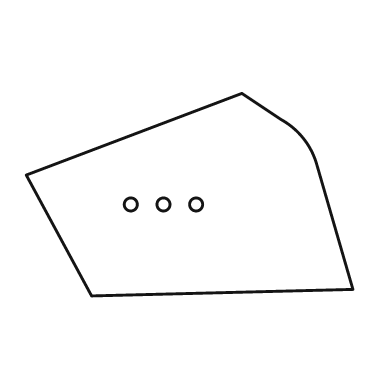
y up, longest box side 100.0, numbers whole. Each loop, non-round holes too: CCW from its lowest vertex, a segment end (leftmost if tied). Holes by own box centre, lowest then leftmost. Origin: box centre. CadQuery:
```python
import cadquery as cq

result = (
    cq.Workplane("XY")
    .moveTo(-30.0, -31.0)
    .lineTo(50.0, -29.0)
    .lineTo(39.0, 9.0)
    .threePointArc((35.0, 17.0), (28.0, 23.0))
    .lineTo(16.0, 31.0)
    .lineTo(-50.0, 6.0)
    .close()
    .moveTo(-18.0, -3.0)
    .circle(2.0)
    .moveTo(-8.0, -3.0)
    .circle(2.0)
    .moveTo(2.0, -3.0)
    .circle(2.0)
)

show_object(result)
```